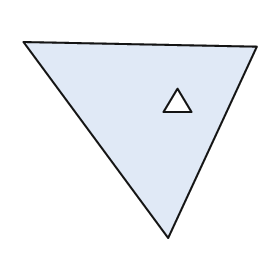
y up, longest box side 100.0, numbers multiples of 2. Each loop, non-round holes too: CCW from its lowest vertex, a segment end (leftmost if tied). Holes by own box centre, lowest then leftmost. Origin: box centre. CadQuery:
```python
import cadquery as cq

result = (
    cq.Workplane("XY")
    .moveTo(12.0, -42.0)
    .lineTo(50.0, 40.0)
    .lineTo(-50.0, 42.0)
    .close()
    .moveTo(10.0, 12.0)
    .lineTo(22.0, 12.0)
    .lineTo(16.0, 22.0)
    .close()
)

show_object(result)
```